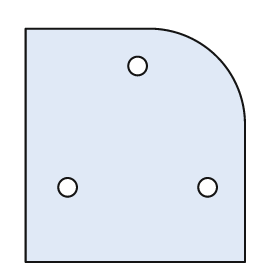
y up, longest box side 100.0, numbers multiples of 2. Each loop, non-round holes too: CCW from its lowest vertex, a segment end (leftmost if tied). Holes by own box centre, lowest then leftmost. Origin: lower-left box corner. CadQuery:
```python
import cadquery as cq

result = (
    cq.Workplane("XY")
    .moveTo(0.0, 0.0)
    .lineTo(94.0, 0.0)
    .lineTo(94.0, 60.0)
    .threePointArc((82.0, 88.0), (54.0, 100.0))
    .lineTo(0.0, 100.0)
    .close()
    .moveTo(18.0, 32.0)
    .circle(4.0)
    .moveTo(78.0, 32.0)
    .circle(4.0)
    .moveTo(48.0, 84.0)
    .circle(4.0)
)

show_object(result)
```